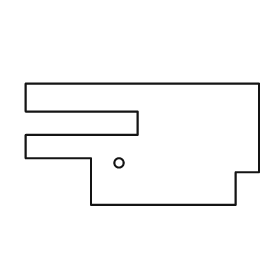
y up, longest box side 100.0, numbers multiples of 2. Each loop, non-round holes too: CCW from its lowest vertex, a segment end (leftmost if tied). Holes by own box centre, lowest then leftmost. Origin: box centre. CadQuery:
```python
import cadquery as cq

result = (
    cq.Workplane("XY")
    .moveTo(-22.0, -26.0)
    .lineTo(40.0, -26.0)
    .lineTo(40.0, -12.0)
    .lineTo(50.0, -12.0)
    .lineTo(50.0, 26.0)
    .lineTo(-50.0, 26.0)
    .lineTo(-50.0, 14.0)
    .lineTo(-2.0, 14.0)
    .lineTo(-2.0, 4.0)
    .lineTo(-50.0, 4.0)
    .lineTo(-50.0, -6.0)
    .lineTo(-22.0, -6.0)
    .close()
    .moveTo(-10.0, -8.0)
    .circle(2.0)
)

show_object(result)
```